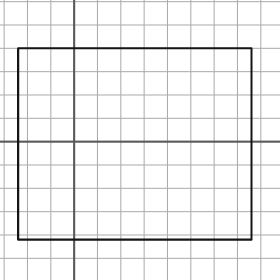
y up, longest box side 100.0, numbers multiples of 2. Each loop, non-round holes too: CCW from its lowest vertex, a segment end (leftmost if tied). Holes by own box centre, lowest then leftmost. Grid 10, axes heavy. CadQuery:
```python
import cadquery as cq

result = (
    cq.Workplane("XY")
    .moveTo(-24.0, -42.0)
    .lineTo(76.0, -42.0)
    .lineTo(76.0, 40.0)
    .lineTo(-24.0, 40.0)
    .close()
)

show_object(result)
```